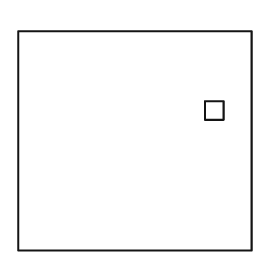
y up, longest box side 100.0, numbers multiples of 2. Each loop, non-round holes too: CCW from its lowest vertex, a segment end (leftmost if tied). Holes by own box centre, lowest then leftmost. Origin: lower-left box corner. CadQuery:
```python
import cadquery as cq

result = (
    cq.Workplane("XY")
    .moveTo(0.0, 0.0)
    .lineTo(100.0, 0.0)
    .lineTo(100.0, 94.0)
    .lineTo(0.0, 94.0)
    .close()
    .moveTo(80.0, 56.0)
    .lineTo(88.0, 56.0)
    .lineTo(88.0, 64.0)
    .lineTo(80.0, 64.0)
    .close()
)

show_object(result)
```